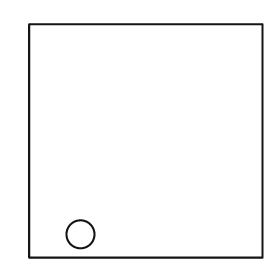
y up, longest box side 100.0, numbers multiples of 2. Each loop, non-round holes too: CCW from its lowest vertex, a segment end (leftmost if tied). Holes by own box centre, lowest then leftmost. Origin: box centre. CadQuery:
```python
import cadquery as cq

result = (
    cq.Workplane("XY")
    .moveTo(-50.0, -50.0)
    .lineTo(50.0, -50.0)
    .lineTo(50.0, 50.0)
    .lineTo(-50.0, 50.0)
    .close()
    .moveTo(-28.0, -40.0)
    .circle(6.0)
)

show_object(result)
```